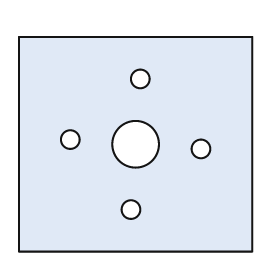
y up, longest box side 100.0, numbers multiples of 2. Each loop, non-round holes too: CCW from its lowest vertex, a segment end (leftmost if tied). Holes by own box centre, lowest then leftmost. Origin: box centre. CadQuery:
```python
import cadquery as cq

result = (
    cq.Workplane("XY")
    .moveTo(-50.0, -46.0)
    .lineTo(50.0, -46.0)
    .lineTo(50.0, 46.0)
    .lineTo(-50.0, 46.0)
    .close()
    .moveTo(-2.0, -28.0)
    .circle(4.0)
    .moveTo(28.0, -2.0)
    .circle(4.0)
    .moveTo(0.0, 0.0)
    .circle(10.0)
    .moveTo(-28.0, 2.0)
    .circle(4.0)
    .moveTo(2.0, 28.0)
    .circle(4.0)
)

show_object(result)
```